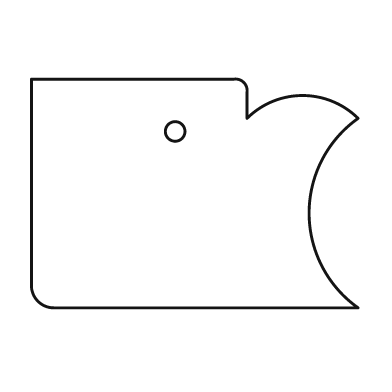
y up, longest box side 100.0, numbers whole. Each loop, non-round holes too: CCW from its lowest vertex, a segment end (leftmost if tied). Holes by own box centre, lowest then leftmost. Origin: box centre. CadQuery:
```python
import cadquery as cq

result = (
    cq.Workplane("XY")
    .moveTo(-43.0, -35.0)
    .lineTo(50.0, -35.0)
    .threePointArc((35.0, -6.0), (50.0, 23.0))
    .threePointArc((33.0, 30.0), (16.0, 23.0))
    .lineTo(16.0, 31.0)
    .threePointArc((15.0, 34.0), (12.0, 35.0))
    .lineTo(-50.0, 35.0)
    .lineTo(-50.0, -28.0)
    .threePointArc((-48.0, -33.0), (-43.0, -35.0))
    .close()
    .moveTo(-6.0, 19.0)
    .circle(3.0)
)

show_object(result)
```